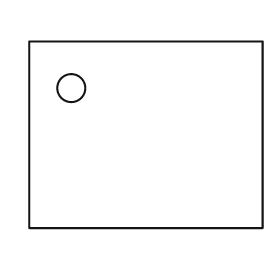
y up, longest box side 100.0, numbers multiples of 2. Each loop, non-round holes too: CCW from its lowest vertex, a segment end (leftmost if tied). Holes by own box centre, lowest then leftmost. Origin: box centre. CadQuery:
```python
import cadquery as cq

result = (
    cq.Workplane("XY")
    .moveTo(-50.0, -40.0)
    .lineTo(50.0, -40.0)
    .lineTo(50.0, 40.0)
    .lineTo(-50.0, 40.0)
    .close()
    .moveTo(-32.0, 20.0)
    .circle(6.0)
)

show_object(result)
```